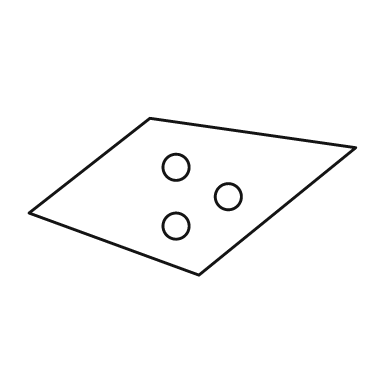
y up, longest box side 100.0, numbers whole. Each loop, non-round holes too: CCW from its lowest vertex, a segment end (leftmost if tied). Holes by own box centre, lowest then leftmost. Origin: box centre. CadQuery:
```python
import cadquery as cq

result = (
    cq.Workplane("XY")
    .moveTo(2.0, -24.0)
    .lineTo(50.0, 15.0)
    .lineTo(-13.0, 24.0)
    .lineTo(-50.0, -5.0)
    .close()
    .moveTo(-5.0, -9.0)
    .circle(4.0)
    .moveTo(11.0, 0.0)
    .circle(4.0)
    .moveTo(-5.0, 9.0)
    .circle(4.0)
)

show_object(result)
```